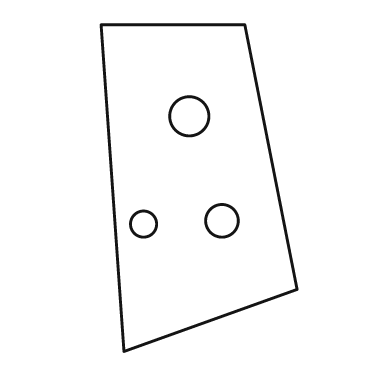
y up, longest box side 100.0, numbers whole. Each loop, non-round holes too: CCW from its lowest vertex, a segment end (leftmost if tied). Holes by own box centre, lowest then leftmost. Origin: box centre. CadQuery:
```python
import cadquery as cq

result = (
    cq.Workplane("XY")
    .moveTo(-23.0, -50.0)
    .lineTo(30.0, -31.0)
    .lineTo(14.0, 50.0)
    .lineTo(-30.0, 50.0)
    .close()
    .moveTo(-17.0, -11.0)
    .circle(4.0)
    .moveTo(7.0, -10.0)
    .circle(5.0)
    .moveTo(-3.0, 22.0)
    .circle(6.0)
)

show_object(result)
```